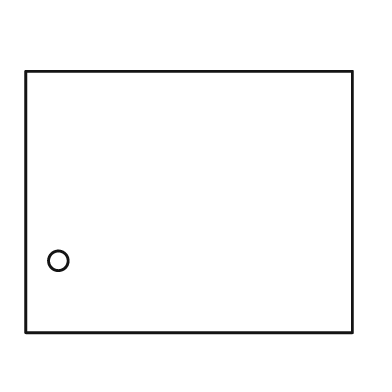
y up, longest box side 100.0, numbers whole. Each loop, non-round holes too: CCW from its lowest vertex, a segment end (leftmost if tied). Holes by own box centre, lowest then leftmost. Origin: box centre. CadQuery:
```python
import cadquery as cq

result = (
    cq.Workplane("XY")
    .moveTo(-50.0, -40.0)
    .lineTo(50.0, -40.0)
    .lineTo(50.0, 40.0)
    .lineTo(-50.0, 40.0)
    .close()
    .moveTo(-40.0, -18.0)
    .circle(3.0)
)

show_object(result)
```